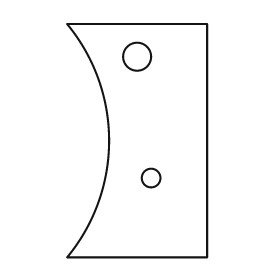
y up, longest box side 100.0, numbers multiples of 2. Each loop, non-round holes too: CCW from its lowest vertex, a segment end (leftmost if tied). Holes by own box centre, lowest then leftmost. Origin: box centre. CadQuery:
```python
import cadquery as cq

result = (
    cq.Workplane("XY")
    .moveTo(-30.0, -50.0)
    .lineTo(30.0, -50.0)
    .lineTo(30.0, 50.0)
    .lineTo(-30.0, 50.0)
    .threePointArc((-12.0, 0.0), (-30.0, -50.0))
    .close()
    .moveTo(6.0, -16.0)
    .circle(4.0)
    .moveTo(0.0, 36.0)
    .circle(6.0)
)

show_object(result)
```